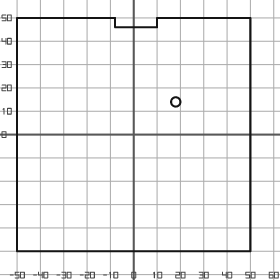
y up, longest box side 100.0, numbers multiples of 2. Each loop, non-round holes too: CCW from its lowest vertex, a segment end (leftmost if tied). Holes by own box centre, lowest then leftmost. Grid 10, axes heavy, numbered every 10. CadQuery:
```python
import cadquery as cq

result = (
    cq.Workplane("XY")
    .moveTo(-50.0, -50.0)
    .lineTo(50.0, -50.0)
    .lineTo(50.0, 50.0)
    .lineTo(10.0, 50.0)
    .lineTo(10.0, 46.0)
    .lineTo(-8.0, 46.0)
    .lineTo(-8.0, 50.0)
    .lineTo(-50.0, 50.0)
    .close()
    .moveTo(18.0, 14.0)
    .circle(2.0)
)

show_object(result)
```